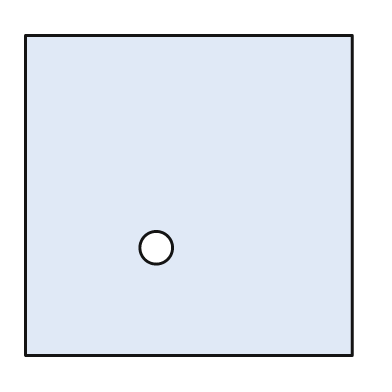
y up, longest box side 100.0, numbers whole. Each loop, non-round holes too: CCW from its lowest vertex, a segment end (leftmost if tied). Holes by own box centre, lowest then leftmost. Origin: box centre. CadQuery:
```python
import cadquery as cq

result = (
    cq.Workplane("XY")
    .moveTo(-50.0, -49.0)
    .lineTo(50.0, -49.0)
    .lineTo(50.0, 49.0)
    .lineTo(-50.0, 49.0)
    .close()
    .moveTo(-10.0, -16.0)
    .circle(5.0)
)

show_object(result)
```